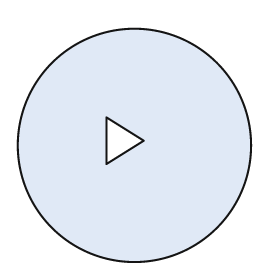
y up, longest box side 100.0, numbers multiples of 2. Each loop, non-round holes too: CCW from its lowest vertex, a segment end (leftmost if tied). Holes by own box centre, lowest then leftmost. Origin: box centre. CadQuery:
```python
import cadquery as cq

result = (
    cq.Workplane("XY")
    .moveTo(0.0, 0.0)
    .circle(50.0)
    .moveTo(-12.0, -8.0)
    .lineTo(4.0, 2.0)
    .lineTo(-12.0, 12.0)
    .close()
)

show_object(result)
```